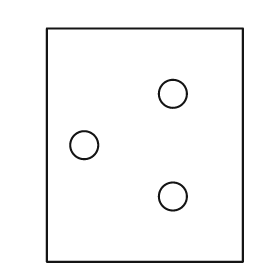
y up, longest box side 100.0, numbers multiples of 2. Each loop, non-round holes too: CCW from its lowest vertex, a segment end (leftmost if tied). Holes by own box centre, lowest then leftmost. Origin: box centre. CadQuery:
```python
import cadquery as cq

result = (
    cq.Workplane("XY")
    .moveTo(-42.0, -50.0)
    .lineTo(42.0, -50.0)
    .lineTo(42.0, 50.0)
    .lineTo(-42.0, 50.0)
    .close()
    .moveTo(12.0, -22.0)
    .circle(6.0)
    .moveTo(-26.0, 0.0)
    .circle(6.0)
    .moveTo(12.0, 22.0)
    .circle(6.0)
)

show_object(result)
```